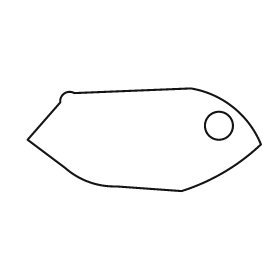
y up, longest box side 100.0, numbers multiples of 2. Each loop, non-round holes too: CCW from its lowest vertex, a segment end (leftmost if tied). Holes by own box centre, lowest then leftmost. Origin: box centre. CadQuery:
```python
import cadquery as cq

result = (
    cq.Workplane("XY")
    .moveTo(16.0, -22.0)
    .threePointArc((34.0, -14.0), (50.0, -2.0))
    .threePointArc((38.0, 14.0), (20.0, 22.0))
    .lineTo(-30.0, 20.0)
    .threePointArc((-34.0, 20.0), (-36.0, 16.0))
    .lineTo(-50.0, 0.0)
    .lineTo(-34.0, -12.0)
    .threePointArc((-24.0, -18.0), (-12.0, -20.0))
    .close()
    .moveTo(32.0, 6.0)
    .circle(6.0)
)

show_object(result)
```